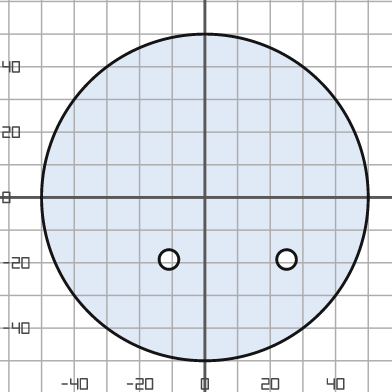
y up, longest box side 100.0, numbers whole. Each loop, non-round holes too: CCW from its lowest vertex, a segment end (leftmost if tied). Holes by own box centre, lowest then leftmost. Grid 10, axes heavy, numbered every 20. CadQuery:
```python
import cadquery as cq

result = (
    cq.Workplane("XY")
    .moveTo(0.0, 0.0)
    .circle(50.0)
    .moveTo(-11.0, -19.0)
    .circle(3.0)
    .moveTo(25.0, -19.0)
    .circle(3.0)
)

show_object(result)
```